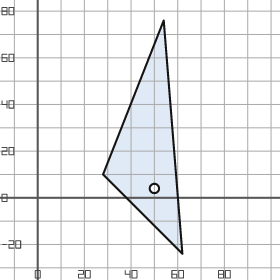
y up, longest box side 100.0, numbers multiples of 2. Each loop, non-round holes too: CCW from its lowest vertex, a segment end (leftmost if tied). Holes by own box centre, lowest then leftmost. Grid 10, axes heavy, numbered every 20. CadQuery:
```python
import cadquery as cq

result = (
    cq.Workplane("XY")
    .moveTo(62.0, -24.0)
    .lineTo(54.0, 76.0)
    .lineTo(28.0, 10.0)
    .close()
    .moveTo(50.0, 4.0)
    .circle(2.0)
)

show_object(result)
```